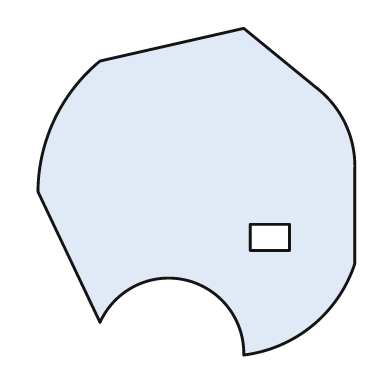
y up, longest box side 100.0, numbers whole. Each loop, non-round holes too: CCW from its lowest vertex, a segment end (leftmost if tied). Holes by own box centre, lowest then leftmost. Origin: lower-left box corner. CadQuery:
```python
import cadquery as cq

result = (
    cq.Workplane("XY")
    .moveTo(63.0, 0.0)
    .threePointArc((84.0, 9.0), (97.0, 28.0))
    .lineTo(97.0, 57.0)
    .threePointArc((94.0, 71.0), (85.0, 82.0))
    .lineTo(63.0, 100.0)
    .lineTo(19.0, 90.0)
    .threePointArc((5.0, 72.0), (0.0, 50.0))
    .lineTo(19.0, 10.0)
    .threePointArc((45.0, 23.0), (63.0, 0.0))
    .close()
    .moveTo(65.0, 32.0)
    .lineTo(77.0, 32.0)
    .lineTo(77.0, 40.0)
    .lineTo(65.0, 40.0)
    .close()
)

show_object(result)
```